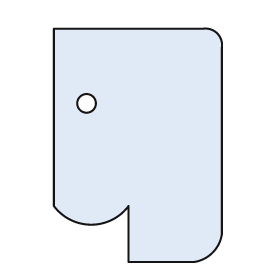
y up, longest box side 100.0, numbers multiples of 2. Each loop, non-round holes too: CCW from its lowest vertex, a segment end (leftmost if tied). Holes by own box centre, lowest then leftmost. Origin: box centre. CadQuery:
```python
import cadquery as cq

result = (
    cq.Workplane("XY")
    .moveTo(-4.0, -50.0)
    .lineTo(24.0, -50.0)
    .threePointArc((32.0, -46.0), (36.0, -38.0))
    .lineTo(36.0, 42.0)
    .threePointArc((34.0, 48.0), (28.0, 50.0))
    .lineTo(-36.0, 50.0)
    .lineTo(-36.0, -26.0)
    .threePointArc((-20.0, -34.0), (-4.0, -26.0))
    .close()
    .moveTo(-22.0, 18.0)
    .circle(4.0)
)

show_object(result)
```